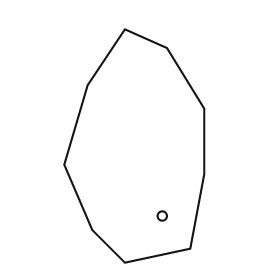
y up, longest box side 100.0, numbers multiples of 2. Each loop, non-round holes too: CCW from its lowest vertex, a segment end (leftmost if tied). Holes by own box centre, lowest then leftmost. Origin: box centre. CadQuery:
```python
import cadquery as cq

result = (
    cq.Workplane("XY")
    .moveTo(-4.0, -50.0)
    .lineTo(24.0, -44.0)
    .lineTo(30.0, -12.0)
    .lineTo(30.0, 16.0)
    .lineTo(14.0, 42.0)
    .lineTo(-4.0, 50.0)
    .lineTo(-20.0, 26.0)
    .lineTo(-30.0, -8.0)
    .lineTo(-18.0, -36.0)
    .close()
    .moveTo(12.0, -30.0)
    .circle(2.0)
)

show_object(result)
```